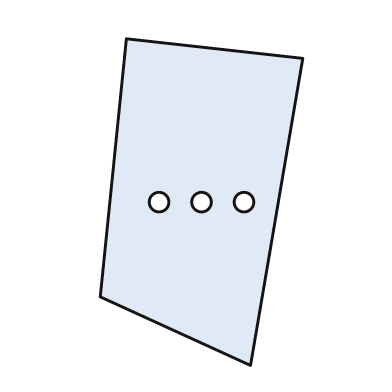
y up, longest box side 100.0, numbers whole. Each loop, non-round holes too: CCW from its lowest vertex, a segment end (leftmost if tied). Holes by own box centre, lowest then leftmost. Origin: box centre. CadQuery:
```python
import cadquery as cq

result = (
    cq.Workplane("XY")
    .moveTo(15.0, -50.0)
    .lineTo(31.0, 44.0)
    .lineTo(-23.0, 50.0)
    .lineTo(-31.0, -29.0)
    .close()
    .moveTo(-13.0, 0.0)
    .circle(3.0)
    .moveTo(0.0, 0.0)
    .circle(3.0)
    .moveTo(13.0, 0.0)
    .circle(3.0)
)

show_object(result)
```